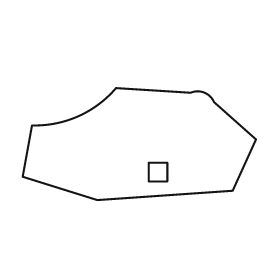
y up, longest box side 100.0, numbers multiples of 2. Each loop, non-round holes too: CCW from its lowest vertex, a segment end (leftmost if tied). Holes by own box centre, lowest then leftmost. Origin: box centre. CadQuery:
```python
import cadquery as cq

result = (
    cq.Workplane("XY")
    .moveTo(-18.0, -24.0)
    .lineTo(40.0, -20.0)
    .lineTo(50.0, 2.0)
    .lineTo(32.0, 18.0)
    .threePointArc((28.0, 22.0), (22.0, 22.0))
    .lineTo(-10.0, 24.0)
    .threePointArc((-26.0, 12.0), (-46.0, 8.0))
    .lineTo(-50.0, -14.0)
    .close()
    .moveTo(4.0, -16.0)
    .lineTo(12.0, -16.0)
    .lineTo(12.0, -8.0)
    .lineTo(4.0, -8.0)
    .close()
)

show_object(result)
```